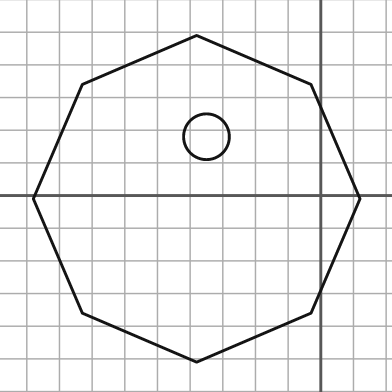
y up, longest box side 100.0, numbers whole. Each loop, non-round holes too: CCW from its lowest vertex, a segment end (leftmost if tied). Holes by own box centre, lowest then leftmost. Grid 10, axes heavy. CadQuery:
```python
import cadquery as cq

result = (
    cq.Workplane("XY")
    .moveTo(-38.0, -51.0)
    .lineTo(-3.0, -36.0)
    .lineTo(12.0, -1.0)
    .lineTo(-3.0, 34.0)
    .lineTo(-38.0, 49.0)
    .lineTo(-73.0, 34.0)
    .lineTo(-88.0, -1.0)
    .lineTo(-73.0, -36.0)
    .close()
    .moveTo(-35.0, 18.0)
    .circle(7.0)
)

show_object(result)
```